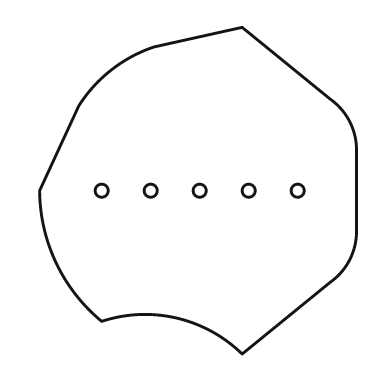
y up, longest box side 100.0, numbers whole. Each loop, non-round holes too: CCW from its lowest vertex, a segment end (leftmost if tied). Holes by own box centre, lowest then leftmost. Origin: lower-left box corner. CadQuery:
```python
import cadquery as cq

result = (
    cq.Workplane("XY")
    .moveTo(62.0, 0.0)
    .lineTo(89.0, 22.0)
    .threePointArc((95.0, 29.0), (97.0, 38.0))
    .lineTo(97.0, 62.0)
    .threePointArc((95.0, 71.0), (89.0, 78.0))
    .lineTo(62.0, 100.0)
    .lineTo(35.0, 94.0)
    .threePointArc((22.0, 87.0), (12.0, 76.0))
    .lineTo(0.0, 50.0)
    .threePointArc((5.0, 28.0), (19.0, 10.0))
    .threePointArc((42.0, 11.0), (62.0, 0.0))
    .close()
    .moveTo(19.0, 50.0)
    .circle(2.0)
    .moveTo(34.0, 50.0)
    .circle(2.0)
    .moveTo(49.0, 50.0)
    .circle(2.0)
    .moveTo(64.0, 50.0)
    .circle(2.0)
    .moveTo(79.0, 50.0)
    .circle(2.0)
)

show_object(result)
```